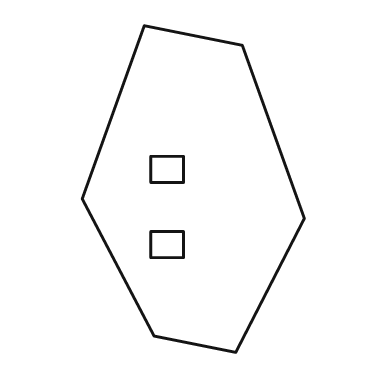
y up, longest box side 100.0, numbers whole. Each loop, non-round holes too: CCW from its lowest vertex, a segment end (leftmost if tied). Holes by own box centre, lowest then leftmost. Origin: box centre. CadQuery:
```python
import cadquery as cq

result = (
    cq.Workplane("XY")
    .moveTo(13.0, -50.0)
    .lineTo(34.0, -9.0)
    .lineTo(15.0, 44.0)
    .lineTo(-15.0, 50.0)
    .lineTo(-34.0, -3.0)
    .lineTo(-12.0, -45.0)
    .close()
    .moveTo(-13.0, -21.0)
    .lineTo(-3.0, -21.0)
    .lineTo(-3.0, -13.0)
    .lineTo(-13.0, -13.0)
    .close()
    .moveTo(-13.0, 2.0)
    .lineTo(-3.0, 2.0)
    .lineTo(-3.0, 10.0)
    .lineTo(-13.0, 10.0)
    .close()
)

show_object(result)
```